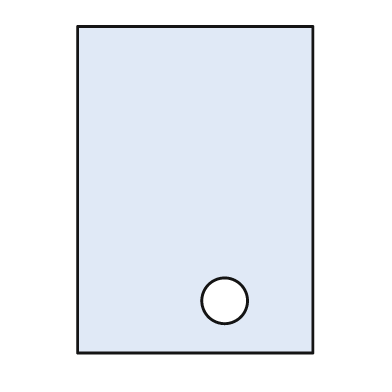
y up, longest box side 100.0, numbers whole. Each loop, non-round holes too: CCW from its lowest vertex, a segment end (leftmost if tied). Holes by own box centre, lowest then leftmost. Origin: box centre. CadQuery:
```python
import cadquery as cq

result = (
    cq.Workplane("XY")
    .moveTo(-36.0, -50.0)
    .lineTo(36.0, -50.0)
    .lineTo(36.0, 50.0)
    .lineTo(-36.0, 50.0)
    .close()
    .moveTo(9.0, -34.0)
    .circle(7.0)
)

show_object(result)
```